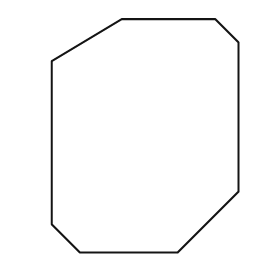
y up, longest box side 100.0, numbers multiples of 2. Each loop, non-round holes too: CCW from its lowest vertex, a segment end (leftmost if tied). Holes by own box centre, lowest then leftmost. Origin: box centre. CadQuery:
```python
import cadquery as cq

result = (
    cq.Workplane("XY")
    .moveTo(-28.0, -50.0)
    .lineTo(14.0, -50.0)
    .lineTo(40.0, -24.0)
    .lineTo(40.0, 40.0)
    .lineTo(30.0, 50.0)
    .lineTo(-10.0, 50.0)
    .lineTo(-40.0, 32.0)
    .lineTo(-40.0, -38.0)
    .close()
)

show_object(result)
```